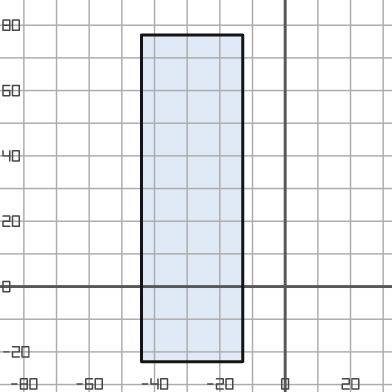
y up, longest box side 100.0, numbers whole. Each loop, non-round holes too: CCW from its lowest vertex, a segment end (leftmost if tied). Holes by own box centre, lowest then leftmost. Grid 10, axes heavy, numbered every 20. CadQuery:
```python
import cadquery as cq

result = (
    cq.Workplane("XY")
    .moveTo(-44.0, -23.0)
    .lineTo(-13.0, -23.0)
    .lineTo(-13.0, 77.0)
    .lineTo(-44.0, 77.0)
    .close()
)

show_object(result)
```